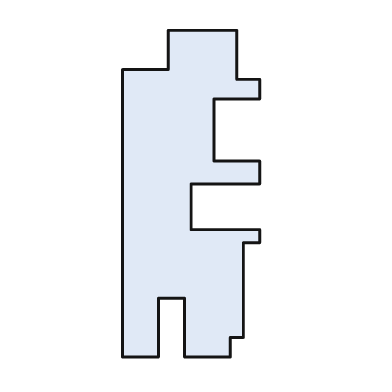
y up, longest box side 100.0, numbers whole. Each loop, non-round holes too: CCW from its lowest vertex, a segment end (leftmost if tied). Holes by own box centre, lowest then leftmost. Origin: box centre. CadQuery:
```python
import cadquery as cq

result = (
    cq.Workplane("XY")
    .moveTo(-21.0, -50.0)
    .lineTo(-10.0, -50.0)
    .lineTo(-10.0, -32.0)
    .lineTo(-2.0, -32.0)
    .lineTo(-2.0, -50.0)
    .lineTo(12.0, -50.0)
    .lineTo(12.0, -44.0)
    .lineTo(16.0, -44.0)
    .lineTo(16.0, -15.0)
    .lineTo(21.0, -15.0)
    .lineTo(21.0, -11.0)
    .lineTo(0.0, -11.0)
    .lineTo(0.0, 3.0)
    .lineTo(21.0, 3.0)
    .lineTo(21.0, 10.0)
    .lineTo(7.0, 10.0)
    .lineTo(7.0, 29.0)
    .lineTo(21.0, 29.0)
    .lineTo(21.0, 35.0)
    .lineTo(14.0, 35.0)
    .lineTo(14.0, 50.0)
    .lineTo(-7.0, 50.0)
    .lineTo(-7.0, 38.0)
    .lineTo(-21.0, 38.0)
    .close()
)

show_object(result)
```